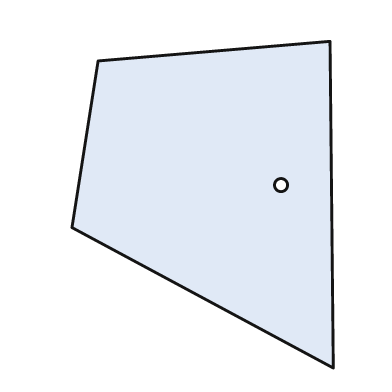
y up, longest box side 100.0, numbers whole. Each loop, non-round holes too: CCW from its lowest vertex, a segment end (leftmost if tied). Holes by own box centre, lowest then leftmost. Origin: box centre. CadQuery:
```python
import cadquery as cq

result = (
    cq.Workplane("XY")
    .moveTo(40.0, -50.0)
    .lineTo(39.0, 50.0)
    .lineTo(-32.0, 44.0)
    .lineTo(-40.0, -7.0)
    .close()
    .moveTo(24.0, 6.0)
    .circle(2.0)
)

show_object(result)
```